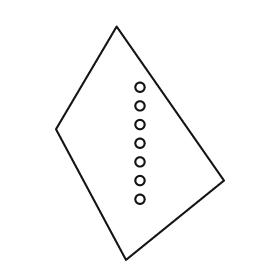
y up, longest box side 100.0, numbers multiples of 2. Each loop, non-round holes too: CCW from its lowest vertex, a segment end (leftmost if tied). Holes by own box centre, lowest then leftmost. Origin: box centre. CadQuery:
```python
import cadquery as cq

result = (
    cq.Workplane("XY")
    .moveTo(-6.0, -50.0)
    .lineTo(36.0, -16.0)
    .lineTo(-10.0, 50.0)
    .lineTo(-36.0, 6.0)
    .close()
    .moveTo(0.0, -24.0)
    .circle(2.0)
    .moveTo(0.0, -16.0)
    .circle(2.0)
    .moveTo(0.0, -8.0)
    .circle(2.0)
    .moveTo(0.0, 0.0)
    .circle(2.0)
    .moveTo(0.0, 8.0)
    .circle(2.0)
    .moveTo(0.0, 16.0)
    .circle(2.0)
    .moveTo(0.0, 24.0)
    .circle(2.0)
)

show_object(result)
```